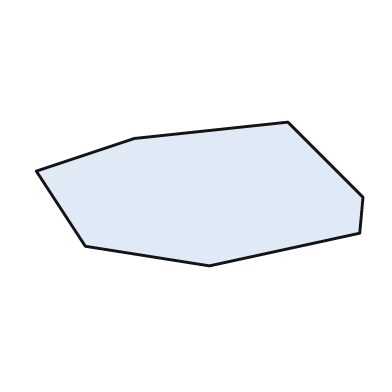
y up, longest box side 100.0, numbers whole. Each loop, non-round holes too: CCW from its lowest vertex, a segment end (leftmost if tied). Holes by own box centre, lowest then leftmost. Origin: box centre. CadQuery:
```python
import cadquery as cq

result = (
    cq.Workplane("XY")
    .moveTo(3.0, -22.0)
    .lineTo(49.0, -12.0)
    .lineTo(50.0, -1.0)
    .lineTo(27.0, 22.0)
    .lineTo(-20.0, 17.0)
    .lineTo(-50.0, 7.0)
    .lineTo(-35.0, -16.0)
    .close()
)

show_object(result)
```